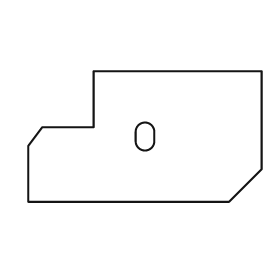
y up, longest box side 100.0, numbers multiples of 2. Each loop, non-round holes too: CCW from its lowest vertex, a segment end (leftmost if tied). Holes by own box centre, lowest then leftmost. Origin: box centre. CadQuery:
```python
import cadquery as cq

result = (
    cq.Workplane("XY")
    .moveTo(-50.0, -28.0)
    .lineTo(36.0, -28.0)
    .lineTo(50.0, -14.0)
    .lineTo(50.0, 28.0)
    .lineTo(-22.0, 28.0)
    .lineTo(-22.0, 4.0)
    .lineTo(-44.0, 4.0)
    .lineTo(-50.0, -4.0)
    .close()
    .moveTo(-4.0, -2.0)
    .threePointArc((0.0, -6.0), (4.0, -2.0))
    .lineTo(4.0, 2.0)
    .threePointArc((0.0, 6.0), (-4.0, 2.0))
    .close()
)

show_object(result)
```